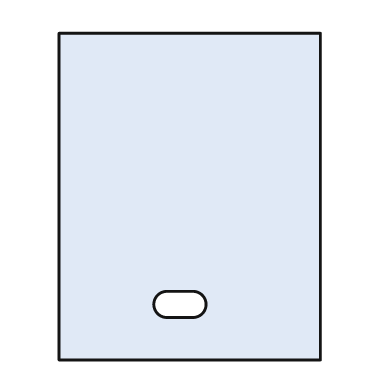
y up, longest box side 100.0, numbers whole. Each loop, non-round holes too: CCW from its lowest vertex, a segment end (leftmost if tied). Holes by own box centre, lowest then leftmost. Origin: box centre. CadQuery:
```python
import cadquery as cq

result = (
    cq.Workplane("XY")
    .moveTo(-40.0, -50.0)
    .lineTo(40.0, -50.0)
    .lineTo(40.0, 50.0)
    .lineTo(-40.0, 50.0)
    .close()
    .moveTo(-7.0, -37.0)
    .lineTo(1.0, -37.0)
    .threePointArc((5.0, -33.0), (1.0, -29.0))
    .lineTo(-7.0, -29.0)
    .threePointArc((-11.0, -33.0), (-7.0, -37.0))
    .close()
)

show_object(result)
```